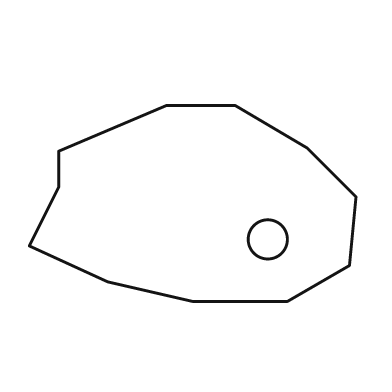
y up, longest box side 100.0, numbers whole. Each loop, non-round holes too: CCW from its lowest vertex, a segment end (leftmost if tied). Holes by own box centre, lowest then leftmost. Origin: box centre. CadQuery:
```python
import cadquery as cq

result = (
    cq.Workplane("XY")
    .moveTo(0.0, -30.0)
    .lineTo(29.0, -30.0)
    .lineTo(48.0, -19.0)
    .lineTo(50.0, 2.0)
    .lineTo(35.0, 17.0)
    .lineTo(13.0, 30.0)
    .lineTo(-8.0, 30.0)
    .lineTo(-41.0, 16.0)
    .lineTo(-41.0, 5.0)
    .lineTo(-50.0, -13.0)
    .lineTo(-26.0, -24.0)
    .close()
    .moveTo(23.0, -11.0)
    .circle(6.0)
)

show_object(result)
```